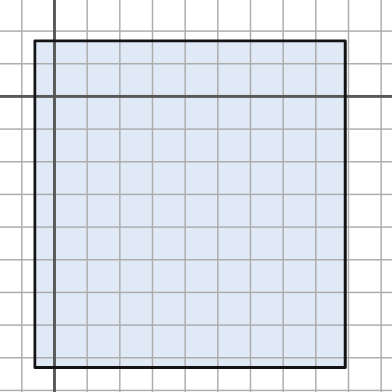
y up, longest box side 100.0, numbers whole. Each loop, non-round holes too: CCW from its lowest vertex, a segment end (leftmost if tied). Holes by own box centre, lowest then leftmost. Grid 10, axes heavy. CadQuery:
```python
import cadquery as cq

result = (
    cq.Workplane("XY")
    .moveTo(-6.0, -83.0)
    .lineTo(89.0, -83.0)
    .lineTo(89.0, 17.0)
    .lineTo(-6.0, 17.0)
    .close()
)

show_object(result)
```